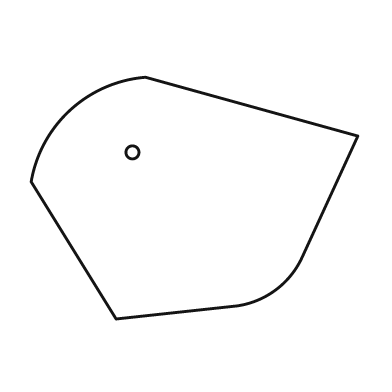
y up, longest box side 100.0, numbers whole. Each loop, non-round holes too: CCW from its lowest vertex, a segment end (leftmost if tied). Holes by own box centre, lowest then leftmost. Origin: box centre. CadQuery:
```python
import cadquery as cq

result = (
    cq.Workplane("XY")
    .moveTo(-24.0, -37.0)
    .lineTo(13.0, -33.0)
    .threePointArc((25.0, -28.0), (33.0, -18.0))
    .lineTo(50.0, 19.0)
    .lineTo(-15.0, 37.0)
    .threePointArc((-38.0, 27.0), (-50.0, 5.0))
    .close()
    .moveTo(-19.0, 14.0)
    .circle(2.0)
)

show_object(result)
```